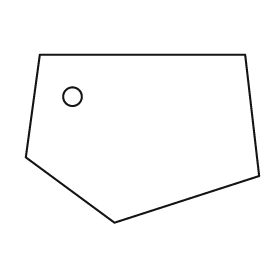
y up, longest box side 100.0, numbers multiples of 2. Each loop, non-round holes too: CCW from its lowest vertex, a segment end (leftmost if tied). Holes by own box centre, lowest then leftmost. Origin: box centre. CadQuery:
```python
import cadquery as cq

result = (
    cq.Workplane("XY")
    .moveTo(-12.0, -36.0)
    .lineTo(50.0, -16.0)
    .lineTo(44.0, 36.0)
    .lineTo(-44.0, 36.0)
    .lineTo(-50.0, -8.0)
    .close()
    .moveTo(-30.0, 18.0)
    .circle(4.0)
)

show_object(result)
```